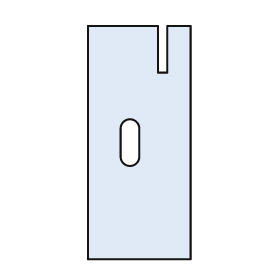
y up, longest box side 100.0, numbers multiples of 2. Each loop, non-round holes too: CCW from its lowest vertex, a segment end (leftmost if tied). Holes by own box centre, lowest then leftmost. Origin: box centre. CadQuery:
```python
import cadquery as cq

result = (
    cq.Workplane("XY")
    .moveTo(-22.0, -50.0)
    .lineTo(22.0, -50.0)
    .lineTo(22.0, 50.0)
    .lineTo(12.0, 50.0)
    .lineTo(12.0, 30.0)
    .lineTo(8.0, 30.0)
    .lineTo(8.0, 50.0)
    .lineTo(-22.0, 50.0)
    .close()
    .moveTo(-8.0, -6.0)
    .threePointArc((-4.0, -10.0), (0.0, -6.0))
    .lineTo(0.0, 6.0)
    .threePointArc((-4.0, 10.0), (-8.0, 6.0))
    .close()
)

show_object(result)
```